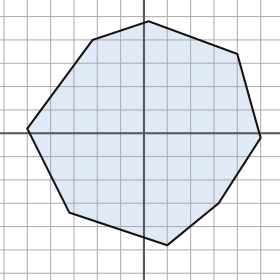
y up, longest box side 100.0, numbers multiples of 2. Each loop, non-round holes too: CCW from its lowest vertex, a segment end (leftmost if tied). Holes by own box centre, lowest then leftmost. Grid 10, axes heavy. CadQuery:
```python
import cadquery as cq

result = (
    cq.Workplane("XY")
    .moveTo(10.0, -48.0)
    .lineTo(32.0, -30.0)
    .lineTo(50.0, -2.0)
    .lineTo(40.0, 34.0)
    .lineTo(2.0, 48.0)
    .lineTo(-22.0, 40.0)
    .lineTo(-50.0, 2.0)
    .lineTo(-32.0, -34.0)
    .close()
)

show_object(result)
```